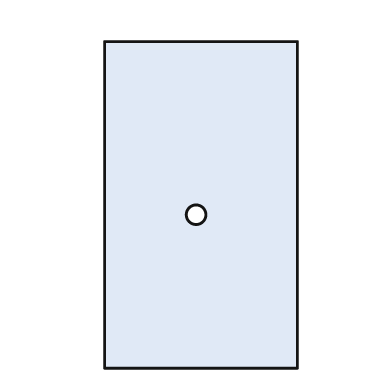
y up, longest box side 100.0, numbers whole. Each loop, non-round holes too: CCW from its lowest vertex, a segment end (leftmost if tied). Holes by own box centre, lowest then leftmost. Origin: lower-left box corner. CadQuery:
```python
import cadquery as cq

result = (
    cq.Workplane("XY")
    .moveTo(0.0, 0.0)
    .lineTo(59.0, 0.0)
    .lineTo(59.0, 100.0)
    .lineTo(0.0, 100.0)
    .close()
    .moveTo(28.0, 47.0)
    .circle(3.0)
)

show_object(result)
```